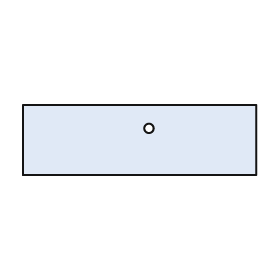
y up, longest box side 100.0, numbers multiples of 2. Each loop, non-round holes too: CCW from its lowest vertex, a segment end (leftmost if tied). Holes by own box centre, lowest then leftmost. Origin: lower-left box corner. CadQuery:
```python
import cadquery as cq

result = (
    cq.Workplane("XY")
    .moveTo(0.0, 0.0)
    .lineTo(100.0, 0.0)
    .lineTo(100.0, 30.0)
    .lineTo(0.0, 30.0)
    .close()
    .moveTo(54.0, 20.0)
    .circle(2.0)
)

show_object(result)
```